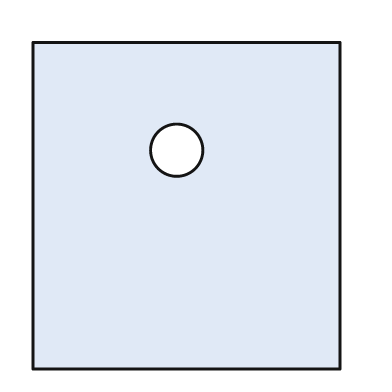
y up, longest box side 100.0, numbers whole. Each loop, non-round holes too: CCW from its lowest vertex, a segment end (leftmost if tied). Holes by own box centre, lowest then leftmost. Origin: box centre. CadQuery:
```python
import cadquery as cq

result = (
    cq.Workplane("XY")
    .moveTo(-47.0, -50.0)
    .lineTo(47.0, -50.0)
    .lineTo(47.0, 50.0)
    .lineTo(-47.0, 50.0)
    .close()
    .moveTo(-3.0, 17.0)
    .circle(8.0)
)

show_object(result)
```